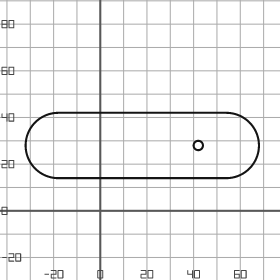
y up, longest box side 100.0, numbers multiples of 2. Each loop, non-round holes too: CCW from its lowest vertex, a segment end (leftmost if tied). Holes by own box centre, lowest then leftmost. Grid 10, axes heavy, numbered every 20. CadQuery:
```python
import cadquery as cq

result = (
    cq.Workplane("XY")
    .moveTo(-18.0, 14.0)
    .lineTo(54.0, 14.0)
    .threePointArc((68.0, 28.0), (54.0, 42.0))
    .lineTo(-18.0, 42.0)
    .threePointArc((-32.0, 28.0), (-18.0, 14.0))
    .close()
    .moveTo(42.0, 28.0)
    .circle(2.0)
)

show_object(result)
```